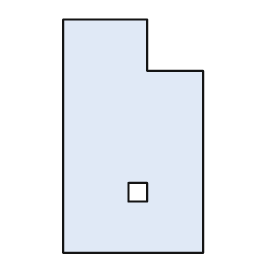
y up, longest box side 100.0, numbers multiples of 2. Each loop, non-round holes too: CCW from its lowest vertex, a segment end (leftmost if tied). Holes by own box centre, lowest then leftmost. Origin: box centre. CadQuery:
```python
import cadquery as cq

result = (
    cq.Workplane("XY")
    .moveTo(-30.0, -50.0)
    .lineTo(30.0, -50.0)
    .lineTo(30.0, 28.0)
    .lineTo(6.0, 28.0)
    .lineTo(6.0, 50.0)
    .lineTo(-30.0, 50.0)
    .close()
    .moveTo(-2.0, -28.0)
    .lineTo(6.0, -28.0)
    .lineTo(6.0, -20.0)
    .lineTo(-2.0, -20.0)
    .close()
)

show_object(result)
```